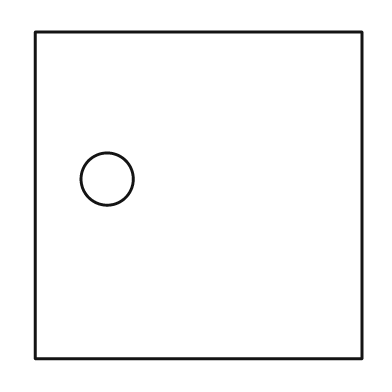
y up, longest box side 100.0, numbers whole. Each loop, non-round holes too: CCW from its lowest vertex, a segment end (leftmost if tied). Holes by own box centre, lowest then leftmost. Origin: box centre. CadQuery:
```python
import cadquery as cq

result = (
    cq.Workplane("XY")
    .moveTo(-50.0, -50.0)
    .lineTo(50.0, -50.0)
    .lineTo(50.0, 50.0)
    .lineTo(-50.0, 50.0)
    .close()
    .moveTo(-28.0, 5.0)
    .circle(8.0)
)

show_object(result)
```